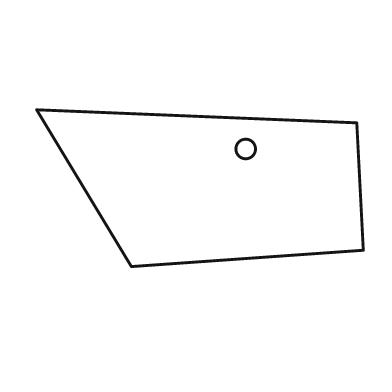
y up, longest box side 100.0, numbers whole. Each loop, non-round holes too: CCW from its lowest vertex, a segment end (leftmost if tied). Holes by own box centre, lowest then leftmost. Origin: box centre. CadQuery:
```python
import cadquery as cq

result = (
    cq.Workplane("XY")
    .moveTo(-21.0, -24.0)
    .lineTo(50.0, -19.0)
    .lineTo(48.0, 20.0)
    .lineTo(-50.0, 24.0)
    .close()
    .moveTo(14.0, 12.0)
    .circle(3.0)
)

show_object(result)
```